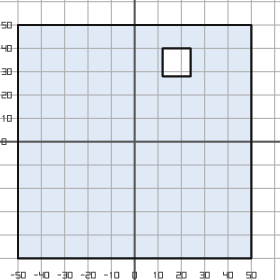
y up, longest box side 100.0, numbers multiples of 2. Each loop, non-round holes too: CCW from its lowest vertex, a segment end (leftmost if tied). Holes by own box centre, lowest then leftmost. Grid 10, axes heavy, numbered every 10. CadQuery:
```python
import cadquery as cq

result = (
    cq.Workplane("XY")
    .moveTo(-50.0, -50.0)
    .lineTo(50.0, -50.0)
    .lineTo(50.0, 50.0)
    .lineTo(-50.0, 50.0)
    .close()
    .moveTo(12.0, 28.0)
    .lineTo(24.0, 28.0)
    .lineTo(24.0, 40.0)
    .lineTo(12.0, 40.0)
    .close()
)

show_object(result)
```